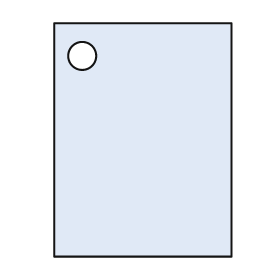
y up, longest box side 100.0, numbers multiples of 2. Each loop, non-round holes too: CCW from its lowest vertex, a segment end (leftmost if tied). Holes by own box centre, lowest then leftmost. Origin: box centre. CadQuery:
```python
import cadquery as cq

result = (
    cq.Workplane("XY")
    .moveTo(-38.0, -50.0)
    .lineTo(38.0, -50.0)
    .lineTo(38.0, 50.0)
    .lineTo(-38.0, 50.0)
    .close()
    .moveTo(-26.0, 36.0)
    .circle(6.0)
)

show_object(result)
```